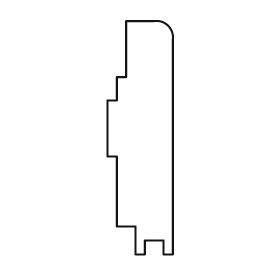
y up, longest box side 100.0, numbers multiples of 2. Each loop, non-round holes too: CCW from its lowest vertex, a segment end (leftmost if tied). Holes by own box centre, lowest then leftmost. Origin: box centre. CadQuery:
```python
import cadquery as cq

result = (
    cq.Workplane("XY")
    .moveTo(-2.0, -50.0)
    .lineTo(2.0, -50.0)
    .lineTo(2.0, -44.0)
    .lineTo(10.0, -44.0)
    .lineTo(10.0, -50.0)
    .lineTo(14.0, -50.0)
    .lineTo(14.0, 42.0)
    .threePointArc((12.0, 48.0), (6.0, 50.0))
    .lineTo(-6.0, 50.0)
    .lineTo(-6.0, 26.0)
    .lineTo(-10.0, 26.0)
    .lineTo(-10.0, 16.0)
    .lineTo(-14.0, 16.0)
    .lineTo(-14.0, -8.0)
    .lineTo(-10.0, -8.0)
    .lineTo(-10.0, -38.0)
    .lineTo(-2.0, -38.0)
    .close()
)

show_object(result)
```